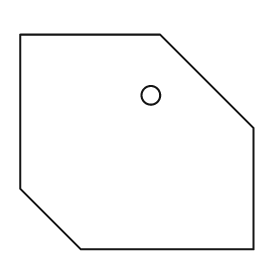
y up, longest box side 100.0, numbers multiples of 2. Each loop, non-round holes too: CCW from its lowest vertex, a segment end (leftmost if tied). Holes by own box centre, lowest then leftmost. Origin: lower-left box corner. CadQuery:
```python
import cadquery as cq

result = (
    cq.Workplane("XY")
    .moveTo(26.0, 0.0)
    .lineTo(100.0, 0.0)
    .lineTo(100.0, 52.0)
    .lineTo(60.0, 92.0)
    .lineTo(0.0, 92.0)
    .lineTo(0.0, 26.0)
    .close()
    .moveTo(56.0, 66.0)
    .circle(4.0)
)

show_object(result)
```